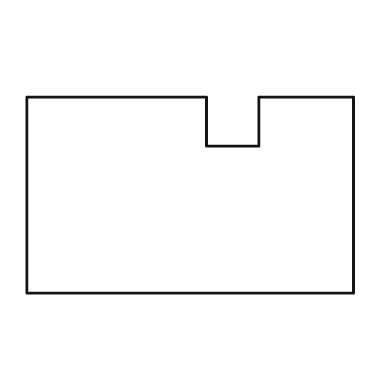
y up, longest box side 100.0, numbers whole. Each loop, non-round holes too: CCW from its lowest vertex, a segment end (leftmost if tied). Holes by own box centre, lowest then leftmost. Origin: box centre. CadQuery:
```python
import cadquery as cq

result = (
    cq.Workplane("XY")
    .moveTo(-50.0, -30.0)
    .lineTo(50.0, -30.0)
    .lineTo(50.0, 30.0)
    .lineTo(21.0, 30.0)
    .lineTo(21.0, 15.0)
    .lineTo(5.0, 15.0)
    .lineTo(5.0, 30.0)
    .lineTo(-50.0, 30.0)
    .close()
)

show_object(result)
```